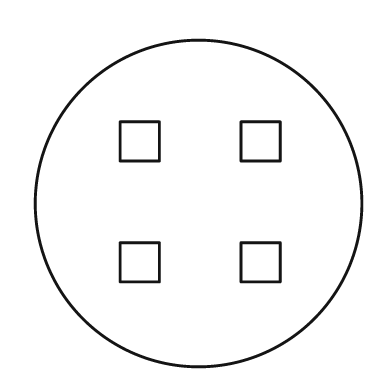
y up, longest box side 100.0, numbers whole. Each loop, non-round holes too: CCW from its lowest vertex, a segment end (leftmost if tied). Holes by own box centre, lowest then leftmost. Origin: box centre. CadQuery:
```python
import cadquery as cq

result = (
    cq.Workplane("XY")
    .moveTo(0.0, 0.0)
    .circle(50.0)
    .moveTo(-24.0, -24.0)
    .lineTo(-12.0, -24.0)
    .lineTo(-12.0, -12.0)
    .lineTo(-24.0, -12.0)
    .close()
    .moveTo(13.0, -24.0)
    .lineTo(25.0, -24.0)
    .lineTo(25.0, -12.0)
    .lineTo(13.0, -12.0)
    .close()
    .moveTo(-24.0, 13.0)
    .lineTo(-12.0, 13.0)
    .lineTo(-12.0, 25.0)
    .lineTo(-24.0, 25.0)
    .close()
    .moveTo(13.0, 13.0)
    .lineTo(25.0, 13.0)
    .lineTo(25.0, 25.0)
    .lineTo(13.0, 25.0)
    .close()
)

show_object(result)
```